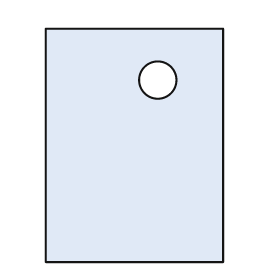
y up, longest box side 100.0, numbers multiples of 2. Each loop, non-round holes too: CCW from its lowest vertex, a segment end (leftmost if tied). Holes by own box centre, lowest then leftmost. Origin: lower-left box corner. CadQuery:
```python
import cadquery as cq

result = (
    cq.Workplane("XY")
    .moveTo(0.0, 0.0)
    .lineTo(76.0, 0.0)
    .lineTo(76.0, 100.0)
    .lineTo(0.0, 100.0)
    .close()
    .moveTo(48.0, 78.0)
    .circle(8.0)
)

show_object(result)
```